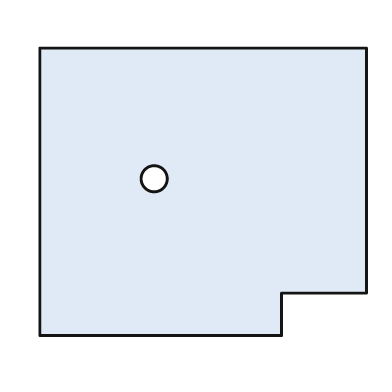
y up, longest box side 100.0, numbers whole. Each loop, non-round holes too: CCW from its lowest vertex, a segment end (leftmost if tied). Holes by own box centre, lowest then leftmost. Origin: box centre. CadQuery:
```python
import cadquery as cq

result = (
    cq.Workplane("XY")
    .moveTo(-50.0, -44.0)
    .lineTo(24.0, -44.0)
    .lineTo(24.0, -31.0)
    .lineTo(50.0, -31.0)
    .lineTo(50.0, 44.0)
    .lineTo(-50.0, 44.0)
    .close()
    .moveTo(-15.0, 4.0)
    .circle(4.0)
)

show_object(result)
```